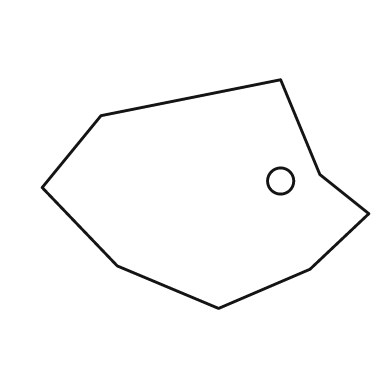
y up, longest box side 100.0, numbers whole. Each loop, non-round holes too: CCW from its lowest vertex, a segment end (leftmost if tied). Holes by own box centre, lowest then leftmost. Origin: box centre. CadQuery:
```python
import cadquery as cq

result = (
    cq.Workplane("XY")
    .moveTo(4.0, -35.0)
    .lineTo(32.0, -23.0)
    .lineTo(50.0, -6.0)
    .lineTo(35.0, 6.0)
    .lineTo(23.0, 35.0)
    .lineTo(-32.0, 24.0)
    .lineTo(-50.0, 2.0)
    .lineTo(-27.0, -22.0)
    .close()
    .moveTo(23.0, 4.0)
    .circle(4.0)
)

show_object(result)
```